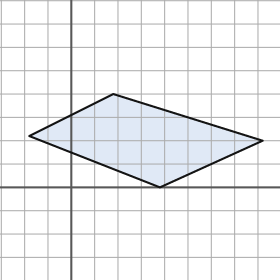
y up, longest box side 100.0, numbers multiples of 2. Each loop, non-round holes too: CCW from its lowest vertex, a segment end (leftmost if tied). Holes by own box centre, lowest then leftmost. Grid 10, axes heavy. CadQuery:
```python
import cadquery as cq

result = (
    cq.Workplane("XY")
    .moveTo(38.0, 0.0)
    .lineTo(82.0, 20.0)
    .lineTo(18.0, 40.0)
    .lineTo(-18.0, 22.0)
    .close()
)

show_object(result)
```